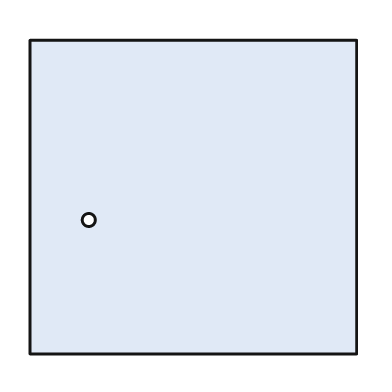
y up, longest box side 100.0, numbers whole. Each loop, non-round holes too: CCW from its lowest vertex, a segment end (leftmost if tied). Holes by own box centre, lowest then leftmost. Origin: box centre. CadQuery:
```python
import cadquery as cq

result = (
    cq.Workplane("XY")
    .moveTo(-50.0, -48.0)
    .lineTo(50.0, -48.0)
    .lineTo(50.0, 48.0)
    .lineTo(-50.0, 48.0)
    .close()
    .moveTo(-32.0, -7.0)
    .circle(2.0)
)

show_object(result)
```